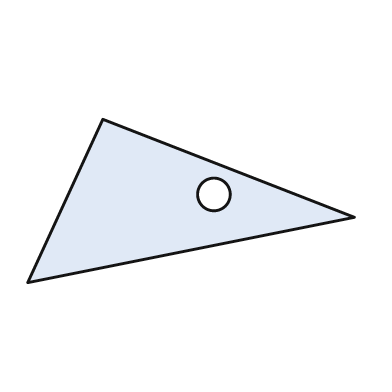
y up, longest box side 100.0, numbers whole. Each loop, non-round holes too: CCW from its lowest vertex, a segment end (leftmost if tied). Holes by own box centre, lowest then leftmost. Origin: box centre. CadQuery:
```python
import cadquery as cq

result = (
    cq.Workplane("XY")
    .moveTo(-50.0, -25.0)
    .lineTo(50.0, -5.0)
    .lineTo(-27.0, 25.0)
    .close()
    .moveTo(7.0, 2.0)
    .circle(5.0)
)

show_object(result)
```